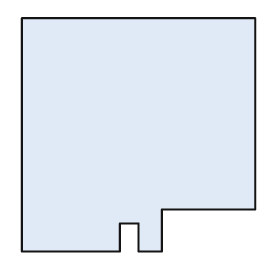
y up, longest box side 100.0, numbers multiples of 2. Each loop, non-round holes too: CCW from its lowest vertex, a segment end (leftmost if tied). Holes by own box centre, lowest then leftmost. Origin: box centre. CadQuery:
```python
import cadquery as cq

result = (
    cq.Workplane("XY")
    .moveTo(-50.0, -50.0)
    .lineTo(-8.0, -50.0)
    .lineTo(-8.0, -38.0)
    .lineTo(0.0, -38.0)
    .lineTo(0.0, -50.0)
    .lineTo(10.0, -50.0)
    .lineTo(10.0, -32.0)
    .lineTo(50.0, -32.0)
    .lineTo(50.0, 50.0)
    .lineTo(-50.0, 50.0)
    .close()
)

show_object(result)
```